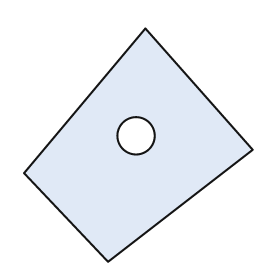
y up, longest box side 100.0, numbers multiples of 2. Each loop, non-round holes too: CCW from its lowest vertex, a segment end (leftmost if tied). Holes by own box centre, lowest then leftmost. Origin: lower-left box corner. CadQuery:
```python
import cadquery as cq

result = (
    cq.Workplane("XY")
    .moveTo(36.0, 0.0)
    .lineTo(98.0, 48.0)
    .lineTo(52.0, 100.0)
    .lineTo(0.0, 38.0)
    .close()
    .moveTo(48.0, 54.0)
    .circle(8.0)
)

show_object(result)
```